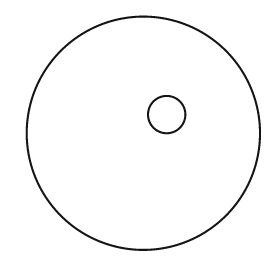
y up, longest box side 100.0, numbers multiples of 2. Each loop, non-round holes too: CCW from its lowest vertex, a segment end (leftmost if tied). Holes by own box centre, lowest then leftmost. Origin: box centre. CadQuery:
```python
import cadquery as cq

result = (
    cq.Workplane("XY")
    .moveTo(0.0, 0.0)
    .circle(50.0)
    .moveTo(10.0, 8.0)
    .circle(8.0)
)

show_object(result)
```